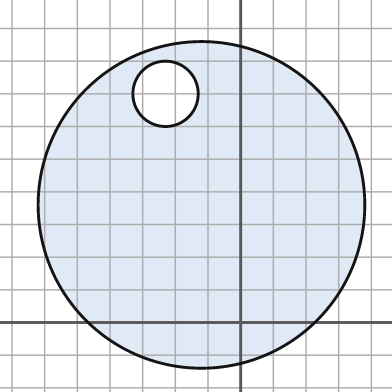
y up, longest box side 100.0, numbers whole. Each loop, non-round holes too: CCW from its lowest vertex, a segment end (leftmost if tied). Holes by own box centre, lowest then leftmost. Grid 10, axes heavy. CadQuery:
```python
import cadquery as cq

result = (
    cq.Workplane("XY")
    .moveTo(-12.0, 36.0)
    .circle(50.0)
    .moveTo(-23.0, 70.0)
    .circle(10.0)
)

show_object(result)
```